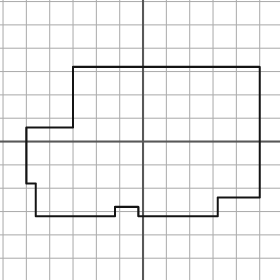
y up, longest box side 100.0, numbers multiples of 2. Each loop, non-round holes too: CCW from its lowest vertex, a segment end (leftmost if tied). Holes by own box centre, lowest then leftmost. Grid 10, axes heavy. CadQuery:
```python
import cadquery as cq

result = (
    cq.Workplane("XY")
    .moveTo(-46.0, -32.0)
    .lineTo(-12.0, -32.0)
    .lineTo(-12.0, -28.0)
    .lineTo(-2.0, -28.0)
    .lineTo(-2.0, -32.0)
    .lineTo(32.0, -32.0)
    .lineTo(32.0, -24.0)
    .lineTo(50.0, -24.0)
    .lineTo(50.0, 32.0)
    .lineTo(-30.0, 32.0)
    .lineTo(-30.0, 6.0)
    .lineTo(-50.0, 6.0)
    .lineTo(-50.0, -18.0)
    .lineTo(-46.0, -18.0)
    .close()
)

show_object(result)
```